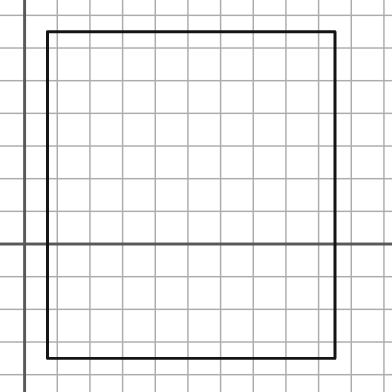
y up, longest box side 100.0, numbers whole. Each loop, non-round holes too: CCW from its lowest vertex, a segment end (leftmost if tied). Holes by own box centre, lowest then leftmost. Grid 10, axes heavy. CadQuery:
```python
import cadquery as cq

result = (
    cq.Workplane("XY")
    .moveTo(7.0, -35.0)
    .lineTo(95.0, -35.0)
    .lineTo(95.0, 65.0)
    .lineTo(7.0, 65.0)
    .close()
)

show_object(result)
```